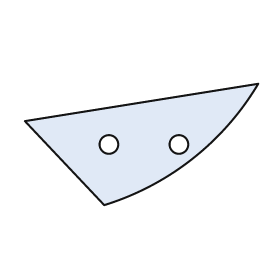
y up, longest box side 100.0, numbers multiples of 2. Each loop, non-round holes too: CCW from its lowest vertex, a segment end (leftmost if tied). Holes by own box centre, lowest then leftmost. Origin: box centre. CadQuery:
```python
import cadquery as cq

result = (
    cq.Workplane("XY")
    .moveTo(-16.0, -26.0)
    .threePointArc((22.0, -6.0), (50.0, 26.0))
    .lineTo(-50.0, 10.0)
    .close()
    .moveTo(-14.0, 0.0)
    .circle(4.0)
    .moveTo(16.0, 0.0)
    .circle(4.0)
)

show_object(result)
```